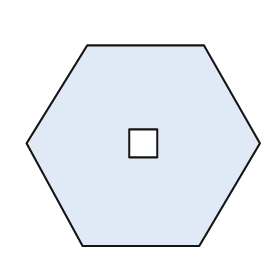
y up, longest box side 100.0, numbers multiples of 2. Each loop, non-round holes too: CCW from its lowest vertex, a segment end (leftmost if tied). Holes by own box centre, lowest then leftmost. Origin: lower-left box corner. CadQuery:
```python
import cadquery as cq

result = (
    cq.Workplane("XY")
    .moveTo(24.0, 0.0)
    .lineTo(74.0, 0.0)
    .lineTo(100.0, 44.0)
    .lineTo(76.0, 86.0)
    .lineTo(26.0, 86.0)
    .lineTo(0.0, 44.0)
    .close()
    .moveTo(44.0, 38.0)
    .lineTo(56.0, 38.0)
    .lineTo(56.0, 50.0)
    .lineTo(44.0, 50.0)
    .close()
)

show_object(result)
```